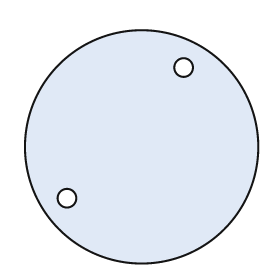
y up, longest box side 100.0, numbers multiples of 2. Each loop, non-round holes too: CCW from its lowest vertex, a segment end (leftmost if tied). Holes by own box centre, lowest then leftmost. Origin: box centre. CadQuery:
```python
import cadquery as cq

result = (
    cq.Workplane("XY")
    .moveTo(0.0, 0.0)
    .circle(50.0)
    .moveTo(-32.0, -22.0)
    .circle(4.0)
    .moveTo(18.0, 34.0)
    .circle(4.0)
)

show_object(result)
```